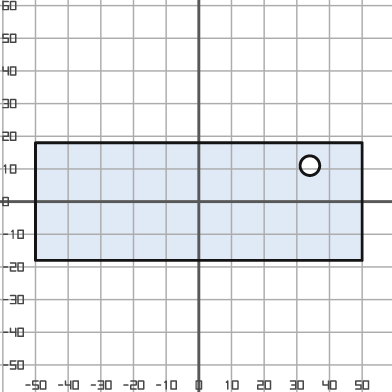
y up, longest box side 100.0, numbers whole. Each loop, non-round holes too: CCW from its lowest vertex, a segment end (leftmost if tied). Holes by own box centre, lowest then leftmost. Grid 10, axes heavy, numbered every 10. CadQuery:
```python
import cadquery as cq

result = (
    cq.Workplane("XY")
    .moveTo(-50.0, -18.0)
    .lineTo(50.0, -18.0)
    .lineTo(50.0, 18.0)
    .lineTo(-50.0, 18.0)
    .close()
    .moveTo(34.0, 11.0)
    .circle(3.0)
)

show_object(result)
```